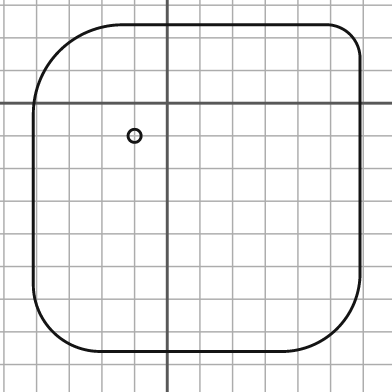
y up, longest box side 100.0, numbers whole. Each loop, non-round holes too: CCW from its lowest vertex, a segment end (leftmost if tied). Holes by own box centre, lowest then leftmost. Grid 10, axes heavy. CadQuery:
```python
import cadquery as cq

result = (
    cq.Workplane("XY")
    .moveTo(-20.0, -76.0)
    .lineTo(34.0, -76.0)
    .threePointArc((52.0, -69.0), (59.0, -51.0))
    .lineTo(59.0, 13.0)
    .threePointArc((56.0, 21.0), (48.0, 24.0))
    .lineTo(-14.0, 24.0)
    .threePointArc((-33.0, 16.0), (-41.0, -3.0))
    .lineTo(-41.0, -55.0)
    .threePointArc((-35.0, -70.0), (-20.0, -76.0))
    .close()
    .moveTo(-10.0, -10.0)
    .circle(2.0)
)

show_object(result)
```